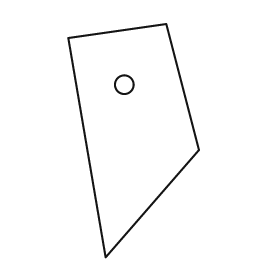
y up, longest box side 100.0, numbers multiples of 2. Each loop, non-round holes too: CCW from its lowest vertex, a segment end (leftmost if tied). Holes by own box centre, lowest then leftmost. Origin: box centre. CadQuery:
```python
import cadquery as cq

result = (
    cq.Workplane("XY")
    .moveTo(-12.0, -50.0)
    .lineTo(28.0, -4.0)
    .lineTo(14.0, 50.0)
    .lineTo(-28.0, 44.0)
    .close()
    .moveTo(-4.0, 24.0)
    .circle(4.0)
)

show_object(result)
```